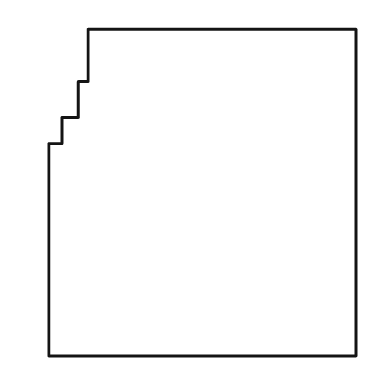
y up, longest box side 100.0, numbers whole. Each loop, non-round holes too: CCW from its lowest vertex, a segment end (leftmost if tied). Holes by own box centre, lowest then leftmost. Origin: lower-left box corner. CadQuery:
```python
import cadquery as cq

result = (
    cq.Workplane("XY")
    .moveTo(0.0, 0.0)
    .lineTo(94.0, 0.0)
    .lineTo(94.0, 100.0)
    .lineTo(12.0, 100.0)
    .lineTo(12.0, 84.0)
    .lineTo(9.0, 84.0)
    .lineTo(9.0, 73.0)
    .lineTo(4.0, 73.0)
    .lineTo(4.0, 65.0)
    .lineTo(0.0, 65.0)
    .close()
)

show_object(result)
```